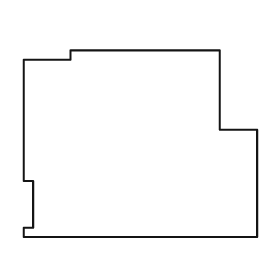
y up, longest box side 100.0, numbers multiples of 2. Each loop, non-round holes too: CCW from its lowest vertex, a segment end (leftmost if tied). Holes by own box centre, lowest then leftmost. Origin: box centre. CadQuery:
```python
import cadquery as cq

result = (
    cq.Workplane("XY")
    .moveTo(-50.0, -40.0)
    .lineTo(50.0, -40.0)
    .lineTo(50.0, 6.0)
    .lineTo(34.0, 6.0)
    .lineTo(34.0, 40.0)
    .lineTo(-30.0, 40.0)
    .lineTo(-30.0, 36.0)
    .lineTo(-50.0, 36.0)
    .lineTo(-50.0, -16.0)
    .lineTo(-46.0, -16.0)
    .lineTo(-46.0, -36.0)
    .lineTo(-50.0, -36.0)
    .close()
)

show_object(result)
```